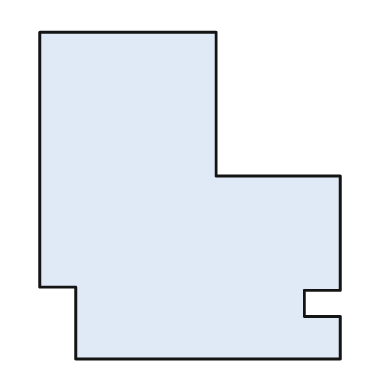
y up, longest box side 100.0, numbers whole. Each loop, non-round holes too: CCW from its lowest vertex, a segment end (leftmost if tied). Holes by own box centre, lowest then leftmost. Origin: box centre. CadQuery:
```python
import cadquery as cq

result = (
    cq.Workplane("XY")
    .moveTo(-35.0, -50.0)
    .lineTo(46.0, -50.0)
    .lineTo(46.0, -37.0)
    .lineTo(35.0, -37.0)
    .lineTo(35.0, -29.0)
    .lineTo(46.0, -29.0)
    .lineTo(46.0, 6.0)
    .lineTo(8.0, 6.0)
    .lineTo(8.0, 50.0)
    .lineTo(-46.0, 50.0)
    .lineTo(-46.0, -28.0)
    .lineTo(-35.0, -28.0)
    .close()
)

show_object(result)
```